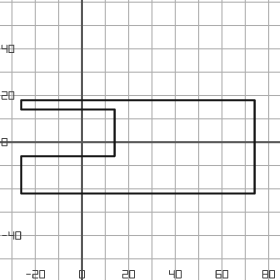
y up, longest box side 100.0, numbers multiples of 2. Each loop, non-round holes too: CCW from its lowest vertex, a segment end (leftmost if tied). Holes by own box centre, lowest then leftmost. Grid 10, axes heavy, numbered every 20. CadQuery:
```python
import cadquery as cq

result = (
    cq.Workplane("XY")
    .moveTo(-26.0, -22.0)
    .lineTo(74.0, -22.0)
    .lineTo(74.0, 18.0)
    .lineTo(-26.0, 18.0)
    .lineTo(-26.0, 14.0)
    .lineTo(14.0, 14.0)
    .lineTo(14.0, -6.0)
    .lineTo(-26.0, -6.0)
    .close()
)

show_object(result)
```